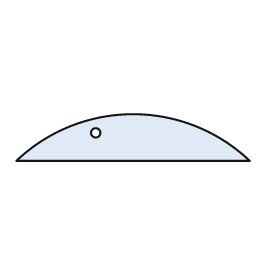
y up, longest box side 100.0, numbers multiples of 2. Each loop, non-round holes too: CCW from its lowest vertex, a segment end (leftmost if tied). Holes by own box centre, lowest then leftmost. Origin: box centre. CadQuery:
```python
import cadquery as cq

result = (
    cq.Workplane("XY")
    .moveTo(-50.0, -10.0)
    .lineTo(50.0, -10.0)
    .threePointArc((0.0, 10.0), (-50.0, -10.0))
    .close()
    .moveTo(-16.0, 2.0)
    .circle(2.0)
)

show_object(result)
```